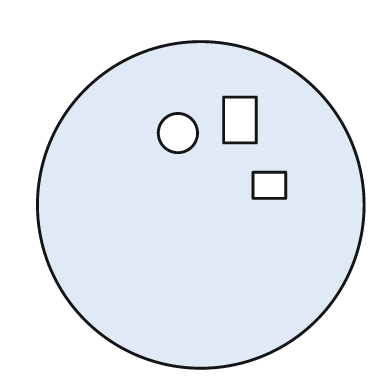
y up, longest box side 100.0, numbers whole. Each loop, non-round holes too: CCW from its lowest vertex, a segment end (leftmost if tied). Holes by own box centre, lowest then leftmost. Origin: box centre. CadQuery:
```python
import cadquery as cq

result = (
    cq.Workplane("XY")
    .moveTo(0.0, 0.0)
    .circle(50.0)
    .moveTo(16.0, 2.0)
    .lineTo(26.0, 2.0)
    .lineTo(26.0, 10.0)
    .lineTo(16.0, 10.0)
    .close()
    .moveTo(-7.0, 22.0)
    .circle(6.0)
    .moveTo(7.0, 19.0)
    .lineTo(17.0, 19.0)
    .lineTo(17.0, 33.0)
    .lineTo(7.0, 33.0)
    .close()
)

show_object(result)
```